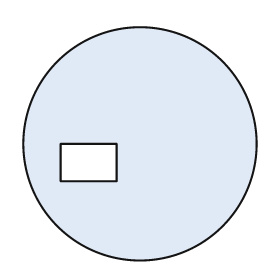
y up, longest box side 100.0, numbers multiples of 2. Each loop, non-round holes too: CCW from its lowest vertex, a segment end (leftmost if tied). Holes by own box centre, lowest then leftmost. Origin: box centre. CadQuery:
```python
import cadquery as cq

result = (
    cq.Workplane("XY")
    .moveTo(0.0, 0.0)
    .circle(50.0)
    .moveTo(-34.0, -16.0)
    .lineTo(-10.0, -16.0)
    .lineTo(-10.0, 0.0)
    .lineTo(-34.0, 0.0)
    .close()
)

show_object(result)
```